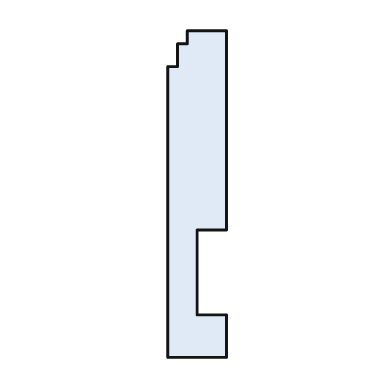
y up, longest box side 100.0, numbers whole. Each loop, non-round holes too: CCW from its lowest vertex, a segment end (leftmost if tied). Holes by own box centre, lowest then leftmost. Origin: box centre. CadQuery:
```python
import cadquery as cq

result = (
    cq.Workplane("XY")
    .moveTo(-9.0, -50.0)
    .lineTo(9.0, -50.0)
    .lineTo(9.0, -37.0)
    .lineTo(0.0, -37.0)
    .lineTo(0.0, -11.0)
    .lineTo(9.0, -11.0)
    .lineTo(9.0, 50.0)
    .lineTo(-3.0, 50.0)
    .lineTo(-3.0, 46.0)
    .lineTo(-6.0, 46.0)
    .lineTo(-6.0, 39.0)
    .lineTo(-9.0, 39.0)
    .close()
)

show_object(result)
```